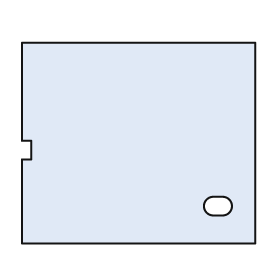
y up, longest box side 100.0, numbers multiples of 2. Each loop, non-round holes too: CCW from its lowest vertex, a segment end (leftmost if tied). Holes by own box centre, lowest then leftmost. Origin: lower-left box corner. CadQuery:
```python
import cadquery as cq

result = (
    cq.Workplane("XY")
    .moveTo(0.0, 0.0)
    .lineTo(100.0, 0.0)
    .lineTo(100.0, 86.0)
    .lineTo(0.0, 86.0)
    .lineTo(0.0, 44.0)
    .lineTo(4.0, 44.0)
    .lineTo(4.0, 36.0)
    .lineTo(0.0, 36.0)
    .close()
    .moveTo(82.0, 12.0)
    .lineTo(86.0, 12.0)
    .threePointArc((90.0, 16.0), (86.0, 20.0))
    .lineTo(82.0, 20.0)
    .threePointArc((78.0, 16.0), (82.0, 12.0))
    .close()
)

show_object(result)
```